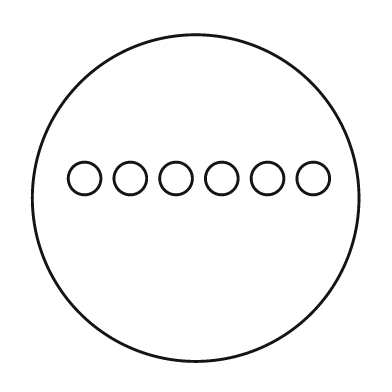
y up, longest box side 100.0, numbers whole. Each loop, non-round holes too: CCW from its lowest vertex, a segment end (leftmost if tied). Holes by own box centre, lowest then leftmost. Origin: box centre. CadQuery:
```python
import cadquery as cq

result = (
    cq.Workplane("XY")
    .moveTo(0.0, 0.0)
    .circle(50.0)
    .moveTo(-34.0, 6.0)
    .circle(5.0)
    .moveTo(-20.0, 6.0)
    .circle(5.0)
    .moveTo(-6.0, 6.0)
    .circle(5.0)
    .moveTo(8.0, 6.0)
    .circle(5.0)
    .moveTo(22.0, 6.0)
    .circle(5.0)
    .moveTo(36.0, 6.0)
    .circle(5.0)
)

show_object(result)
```